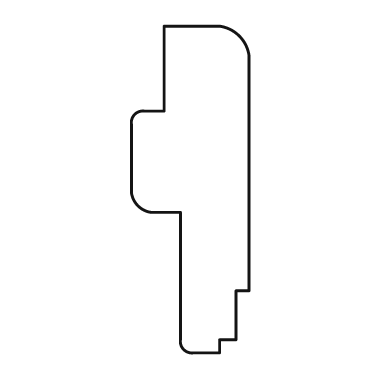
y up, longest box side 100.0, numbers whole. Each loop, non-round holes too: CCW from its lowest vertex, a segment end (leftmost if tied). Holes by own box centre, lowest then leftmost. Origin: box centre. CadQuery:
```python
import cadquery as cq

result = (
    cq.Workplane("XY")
    .moveTo(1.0, -50.0)
    .lineTo(9.0, -50.0)
    .lineTo(9.0, -46.0)
    .lineTo(14.0, -46.0)
    .lineTo(14.0, -31.0)
    .lineTo(18.0, -31.0)
    .lineTo(18.0, 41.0)
    .threePointArc((15.0, 47.0), (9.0, 50.0))
    .lineTo(-8.0, 50.0)
    .lineTo(-8.0, 24.0)
    .lineTo(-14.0, 24.0)
    .threePointArc((-17.0, 23.0), (-18.0, 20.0))
    .lineTo(-18.0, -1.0)
    .threePointArc((-16.0, -5.0), (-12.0, -7.0))
    .lineTo(-3.0, -7.0)
    .lineTo(-3.0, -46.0)
    .threePointArc((-2.0, -49.0), (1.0, -50.0))
    .close()
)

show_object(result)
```